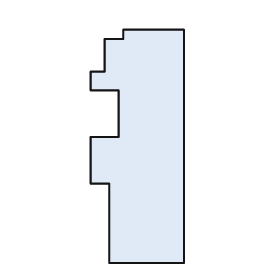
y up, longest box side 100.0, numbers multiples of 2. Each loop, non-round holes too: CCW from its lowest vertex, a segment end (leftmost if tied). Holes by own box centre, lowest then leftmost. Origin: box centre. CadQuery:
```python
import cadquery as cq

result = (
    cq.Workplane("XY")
    .moveTo(-12.0, -50.0)
    .lineTo(20.0, -50.0)
    .lineTo(20.0, 50.0)
    .lineTo(-6.0, 50.0)
    .lineTo(-6.0, 46.0)
    .lineTo(-14.0, 46.0)
    .lineTo(-14.0, 32.0)
    .lineTo(-20.0, 32.0)
    .lineTo(-20.0, 24.0)
    .lineTo(-8.0, 24.0)
    .lineTo(-8.0, 4.0)
    .lineTo(-20.0, 4.0)
    .lineTo(-20.0, -16.0)
    .lineTo(-12.0, -16.0)
    .close()
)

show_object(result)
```